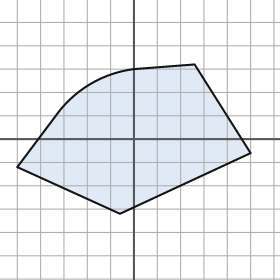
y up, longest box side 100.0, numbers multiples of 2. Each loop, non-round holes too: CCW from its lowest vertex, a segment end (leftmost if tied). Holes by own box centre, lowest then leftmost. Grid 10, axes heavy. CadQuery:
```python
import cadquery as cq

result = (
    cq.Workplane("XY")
    .moveTo(-6.0, -32.0)
    .lineTo(50.0, -6.0)
    .lineTo(26.0, 32.0)
    .lineTo(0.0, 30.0)
    .threePointArc((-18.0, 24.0), (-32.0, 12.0))
    .lineTo(-50.0, -12.0)
    .close()
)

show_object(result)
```